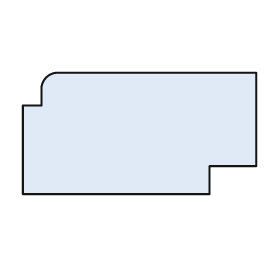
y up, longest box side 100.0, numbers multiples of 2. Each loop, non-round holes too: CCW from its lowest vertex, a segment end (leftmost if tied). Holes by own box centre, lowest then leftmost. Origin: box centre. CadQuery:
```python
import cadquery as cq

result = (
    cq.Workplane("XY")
    .moveTo(-50.0, -26.0)
    .lineTo(30.0, -26.0)
    .lineTo(30.0, -14.0)
    .lineTo(50.0, -14.0)
    .lineTo(50.0, 26.0)
    .lineTo(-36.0, 26.0)
    .threePointArc((-40.0, 24.0), (-42.0, 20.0))
    .lineTo(-42.0, 12.0)
    .lineTo(-50.0, 12.0)
    .close()
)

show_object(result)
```